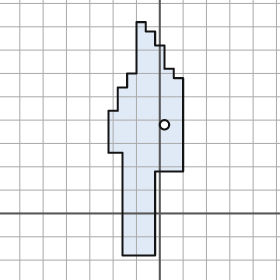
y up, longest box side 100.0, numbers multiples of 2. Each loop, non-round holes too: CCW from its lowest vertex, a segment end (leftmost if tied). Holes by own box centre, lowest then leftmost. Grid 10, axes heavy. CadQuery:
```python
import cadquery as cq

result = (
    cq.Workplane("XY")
    .moveTo(-16.0, -18.0)
    .lineTo(-2.0, -18.0)
    .lineTo(-2.0, 18.0)
    .lineTo(10.0, 18.0)
    .lineTo(10.0, 58.0)
    .lineTo(6.0, 58.0)
    .lineTo(6.0, 62.0)
    .lineTo(2.0, 62.0)
    .lineTo(2.0, 72.0)
    .lineTo(-2.0, 72.0)
    .lineTo(-2.0, 78.0)
    .lineTo(-6.0, 78.0)
    .lineTo(-6.0, 82.0)
    .lineTo(-10.0, 82.0)
    .lineTo(-10.0, 60.0)
    .lineTo(-14.0, 60.0)
    .lineTo(-14.0, 54.0)
    .lineTo(-18.0, 54.0)
    .lineTo(-18.0, 44.0)
    .lineTo(-22.0, 44.0)
    .lineTo(-22.0, 26.0)
    .lineTo(-16.0, 26.0)
    .close()
    .moveTo(2.0, 38.0)
    .circle(2.0)
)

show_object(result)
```